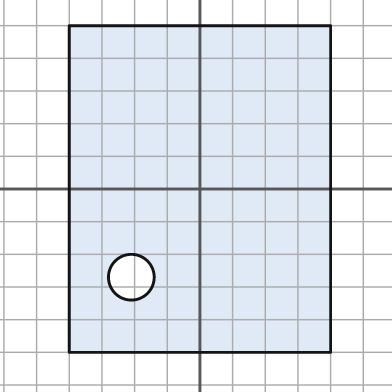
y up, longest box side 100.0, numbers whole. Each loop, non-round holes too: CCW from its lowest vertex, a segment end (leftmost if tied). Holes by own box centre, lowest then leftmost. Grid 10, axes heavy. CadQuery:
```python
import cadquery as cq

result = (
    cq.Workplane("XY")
    .moveTo(-40.0, -50.0)
    .lineTo(40.0, -50.0)
    .lineTo(40.0, 50.0)
    .lineTo(-40.0, 50.0)
    .close()
    .moveTo(-21.0, -27.0)
    .circle(7.0)
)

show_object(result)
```